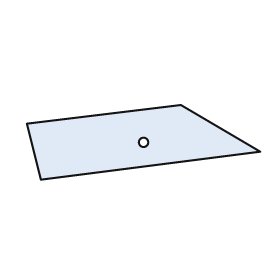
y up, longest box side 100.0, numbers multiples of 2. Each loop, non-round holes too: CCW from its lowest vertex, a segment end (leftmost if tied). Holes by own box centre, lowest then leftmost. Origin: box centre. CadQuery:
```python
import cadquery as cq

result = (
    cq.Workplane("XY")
    .moveTo(-44.0, -16.0)
    .lineTo(50.0, -4.0)
    .lineTo(16.0, 16.0)
    .lineTo(-50.0, 8.0)
    .close()
    .moveTo(0.0, 0.0)
    .circle(2.0)
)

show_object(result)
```